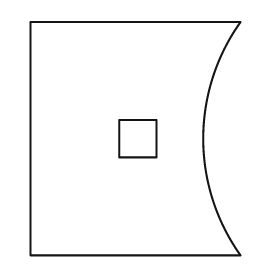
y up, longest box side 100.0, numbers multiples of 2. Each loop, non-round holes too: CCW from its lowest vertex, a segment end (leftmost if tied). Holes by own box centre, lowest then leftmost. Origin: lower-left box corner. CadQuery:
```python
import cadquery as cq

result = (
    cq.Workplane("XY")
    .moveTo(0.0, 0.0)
    .lineTo(90.0, 0.0)
    .threePointArc((74.0, 50.0), (90.0, 100.0))
    .lineTo(0.0, 100.0)
    .close()
    .moveTo(38.0, 42.0)
    .lineTo(54.0, 42.0)
    .lineTo(54.0, 58.0)
    .lineTo(38.0, 58.0)
    .close()
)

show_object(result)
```